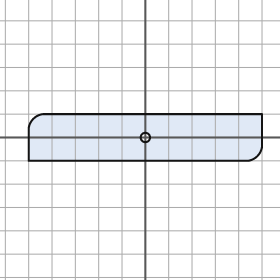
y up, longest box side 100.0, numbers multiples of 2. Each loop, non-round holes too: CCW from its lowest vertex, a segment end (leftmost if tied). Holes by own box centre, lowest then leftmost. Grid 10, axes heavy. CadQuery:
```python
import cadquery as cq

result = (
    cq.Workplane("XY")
    .moveTo(-50.0, -10.0)
    .lineTo(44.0, -10.0)
    .threePointArc((48.0, -8.0), (50.0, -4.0))
    .lineTo(50.0, 10.0)
    .lineTo(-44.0, 10.0)
    .threePointArc((-48.0, 8.0), (-50.0, 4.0))
    .close()
    .moveTo(0.0, 0.0)
    .circle(2.0)
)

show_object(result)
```